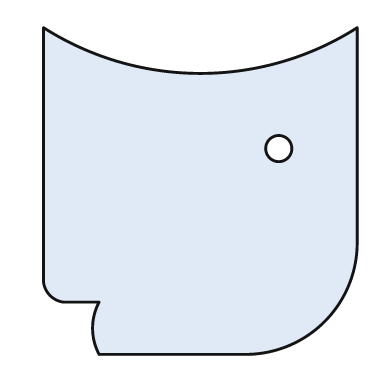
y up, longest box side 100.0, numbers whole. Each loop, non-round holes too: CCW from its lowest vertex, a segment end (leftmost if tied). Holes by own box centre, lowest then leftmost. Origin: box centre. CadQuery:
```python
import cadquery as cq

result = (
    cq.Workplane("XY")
    .moveTo(-31.0, -50.0)
    .lineTo(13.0, -50.0)
    .threePointArc((38.0, -40.0), (48.0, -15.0))
    .lineTo(48.0, 50.0)
    .threePointArc((0.0, 36.0), (-48.0, 50.0))
    .lineTo(-48.0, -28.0)
    .threePointArc((-46.0, -32.0), (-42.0, -34.0))
    .lineTo(-31.0, -34.0)
    .threePointArc((-33.0, -42.0), (-31.0, -50.0))
    .close()
    .moveTo(24.0, 13.0)
    .circle(4.0)
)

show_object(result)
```